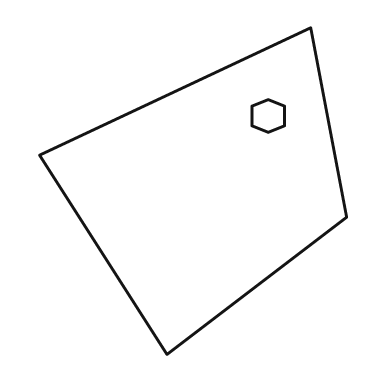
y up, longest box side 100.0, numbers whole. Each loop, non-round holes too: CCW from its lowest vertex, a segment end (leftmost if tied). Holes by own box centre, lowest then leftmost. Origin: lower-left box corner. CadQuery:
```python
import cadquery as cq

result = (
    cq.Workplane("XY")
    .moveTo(39.0, 0.0)
    .lineTo(94.0, 42.0)
    .lineTo(83.0, 100.0)
    .lineTo(0.0, 61.0)
    .close()
    .moveTo(70.0, 68.0)
    .lineTo(75.0, 70.0)
    .lineTo(75.0, 76.0)
    .lineTo(70.0, 78.0)
    .lineTo(65.0, 76.0)
    .lineTo(65.0, 70.0)
    .close()
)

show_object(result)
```